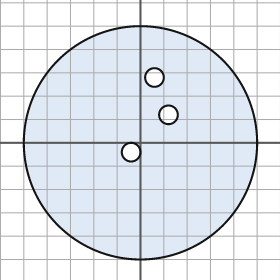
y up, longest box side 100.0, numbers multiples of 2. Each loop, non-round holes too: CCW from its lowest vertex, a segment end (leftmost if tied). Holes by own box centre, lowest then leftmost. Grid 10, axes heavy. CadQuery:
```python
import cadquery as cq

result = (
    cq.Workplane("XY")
    .moveTo(0.0, 0.0)
    .circle(50.0)
    .moveTo(-4.0, -4.0)
    .circle(4.0)
    .moveTo(12.0, 12.0)
    .circle(4.0)
    .moveTo(6.0, 28.0)
    .circle(4.0)
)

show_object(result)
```